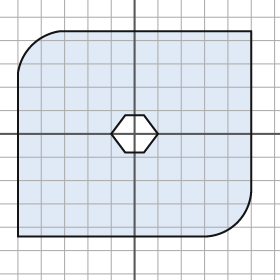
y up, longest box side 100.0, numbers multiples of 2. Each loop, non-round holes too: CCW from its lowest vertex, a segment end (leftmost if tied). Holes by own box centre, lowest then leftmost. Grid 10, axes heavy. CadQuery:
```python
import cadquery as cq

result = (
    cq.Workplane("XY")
    .moveTo(-50.0, -44.0)
    .lineTo(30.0, -44.0)
    .threePointArc((44.0, -38.0), (50.0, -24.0))
    .lineTo(50.0, 44.0)
    .lineTo(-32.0, 44.0)
    .threePointArc((-44.0, 38.0), (-50.0, 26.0))
    .close()
    .moveTo(-4.0, -8.0)
    .lineTo(4.0, -8.0)
    .lineTo(10.0, 0.0)
    .lineTo(4.0, 8.0)
    .lineTo(-4.0, 8.0)
    .lineTo(-10.0, 0.0)
    .close()
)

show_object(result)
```